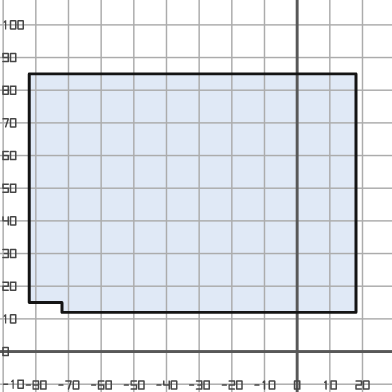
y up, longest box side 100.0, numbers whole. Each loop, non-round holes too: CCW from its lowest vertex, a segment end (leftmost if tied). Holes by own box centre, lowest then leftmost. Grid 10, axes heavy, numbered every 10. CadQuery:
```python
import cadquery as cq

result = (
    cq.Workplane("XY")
    .moveTo(-72.0, 12.0)
    .lineTo(18.0, 12.0)
    .lineTo(18.0, 85.0)
    .lineTo(-82.0, 85.0)
    .lineTo(-82.0, 15.0)
    .lineTo(-72.0, 15.0)
    .close()
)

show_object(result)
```